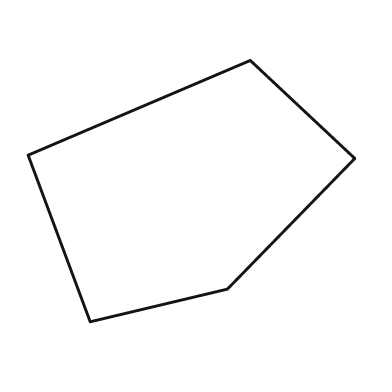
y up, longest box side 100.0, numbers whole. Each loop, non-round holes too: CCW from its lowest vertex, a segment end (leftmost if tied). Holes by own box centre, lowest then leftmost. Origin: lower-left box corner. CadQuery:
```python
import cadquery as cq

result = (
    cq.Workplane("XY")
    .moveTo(19.0, 0.0)
    .lineTo(61.0, 10.0)
    .lineTo(100.0, 50.0)
    .lineTo(68.0, 80.0)
    .lineTo(0.0, 51.0)
    .close()
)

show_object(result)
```